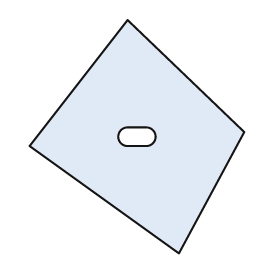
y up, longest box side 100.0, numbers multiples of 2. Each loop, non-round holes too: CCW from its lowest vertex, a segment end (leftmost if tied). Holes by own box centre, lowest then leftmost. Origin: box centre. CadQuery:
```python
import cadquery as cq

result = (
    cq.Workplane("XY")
    .moveTo(18.0, -50.0)
    .lineTo(46.0, 2.0)
    .lineTo(-4.0, 50.0)
    .lineTo(-46.0, -4.0)
    .close()
    .moveTo(-4.0, -4.0)
    .lineTo(4.0, -4.0)
    .threePointArc((8.0, 0.0), (4.0, 4.0))
    .lineTo(-4.0, 4.0)
    .threePointArc((-8.0, 0.0), (-4.0, -4.0))
    .close()
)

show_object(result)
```